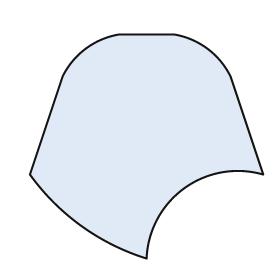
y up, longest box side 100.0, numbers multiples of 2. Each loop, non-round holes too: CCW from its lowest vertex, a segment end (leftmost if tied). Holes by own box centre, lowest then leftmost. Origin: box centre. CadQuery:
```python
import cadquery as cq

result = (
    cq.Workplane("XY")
    .moveTo(0.0, -48.0)
    .threePointArc((16.0, -18.0), (50.0, -12.0))
    .lineTo(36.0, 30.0)
    .threePointArc((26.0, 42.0), (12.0, 48.0))
    .lineTo(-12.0, 48.0)
    .threePointArc((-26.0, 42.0), (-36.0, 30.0))
    .lineTo(-50.0, -12.0)
    .threePointArc((-28.0, -34.0), (0.0, -48.0))
    .close()
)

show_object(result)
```